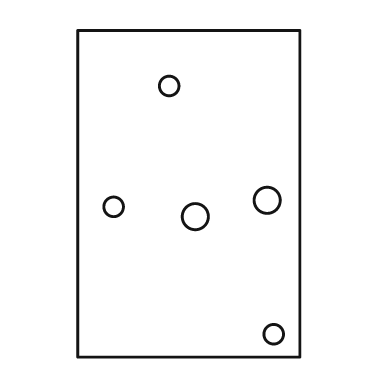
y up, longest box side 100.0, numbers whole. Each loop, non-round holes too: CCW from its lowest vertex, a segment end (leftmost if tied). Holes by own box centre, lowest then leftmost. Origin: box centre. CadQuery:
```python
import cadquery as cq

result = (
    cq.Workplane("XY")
    .moveTo(-34.0, -50.0)
    .lineTo(34.0, -50.0)
    .lineTo(34.0, 50.0)
    .lineTo(-34.0, 50.0)
    .close()
    .moveTo(26.0, -43.0)
    .circle(3.0)
    .moveTo(2.0, -7.0)
    .circle(4.0)
    .moveTo(-23.0, -4.0)
    .circle(3.0)
    .moveTo(24.0, -2.0)
    .circle(4.0)
    .moveTo(-6.0, 33.0)
    .circle(3.0)
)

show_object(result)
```